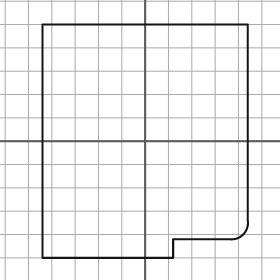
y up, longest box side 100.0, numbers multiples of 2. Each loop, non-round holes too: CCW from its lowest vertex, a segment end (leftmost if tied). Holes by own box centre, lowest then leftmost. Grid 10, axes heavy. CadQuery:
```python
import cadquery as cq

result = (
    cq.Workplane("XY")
    .moveTo(-44.0, -50.0)
    .lineTo(12.0, -50.0)
    .lineTo(12.0, -42.0)
    .lineTo(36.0, -42.0)
    .threePointArc((42.0, -40.0), (44.0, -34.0))
    .lineTo(44.0, 50.0)
    .lineTo(-44.0, 50.0)
    .close()
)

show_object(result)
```